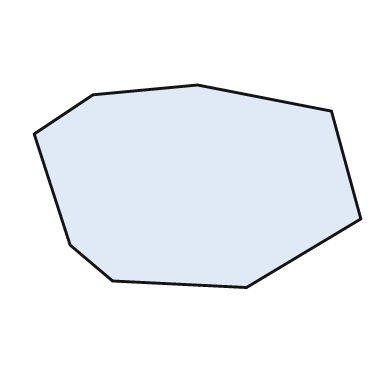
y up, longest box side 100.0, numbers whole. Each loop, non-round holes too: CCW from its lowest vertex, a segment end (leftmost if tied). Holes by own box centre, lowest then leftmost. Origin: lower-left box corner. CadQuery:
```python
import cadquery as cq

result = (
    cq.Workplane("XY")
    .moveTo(65.0, 0.0)
    .lineTo(100.0, 21.0)
    .lineTo(91.0, 54.0)
    .lineTo(50.0, 62.0)
    .lineTo(18.0, 59.0)
    .lineTo(0.0, 47.0)
    .lineTo(11.0, 13.0)
    .lineTo(24.0, 2.0)
    .close()
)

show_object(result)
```